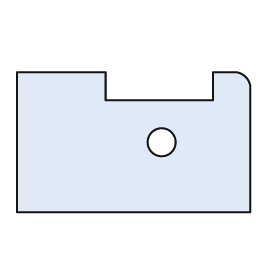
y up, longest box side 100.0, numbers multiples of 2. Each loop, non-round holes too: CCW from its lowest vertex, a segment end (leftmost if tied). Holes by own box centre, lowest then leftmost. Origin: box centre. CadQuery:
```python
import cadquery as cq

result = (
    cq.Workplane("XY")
    .moveTo(-50.0, -30.0)
    .lineTo(50.0, -30.0)
    .lineTo(50.0, 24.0)
    .threePointArc((48.0, 28.0), (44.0, 30.0))
    .lineTo(34.0, 30.0)
    .lineTo(34.0, 18.0)
    .lineTo(-12.0, 18.0)
    .lineTo(-12.0, 30.0)
    .lineTo(-50.0, 30.0)
    .close()
    .moveTo(12.0, 0.0)
    .circle(6.0)
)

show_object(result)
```